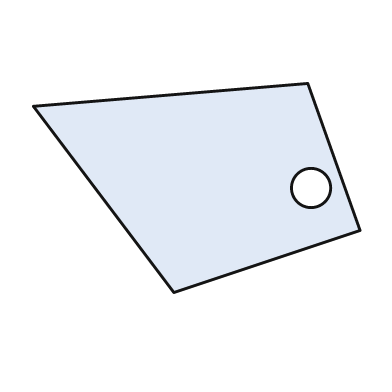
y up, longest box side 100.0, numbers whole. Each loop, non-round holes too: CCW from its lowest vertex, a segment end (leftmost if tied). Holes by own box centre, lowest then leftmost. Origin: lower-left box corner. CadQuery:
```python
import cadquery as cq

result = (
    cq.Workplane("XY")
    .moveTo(43.0, 0.0)
    .lineTo(100.0, 19.0)
    .lineTo(84.0, 64.0)
    .lineTo(0.0, 57.0)
    .close()
    .moveTo(85.0, 32.0)
    .circle(6.0)
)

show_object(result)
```